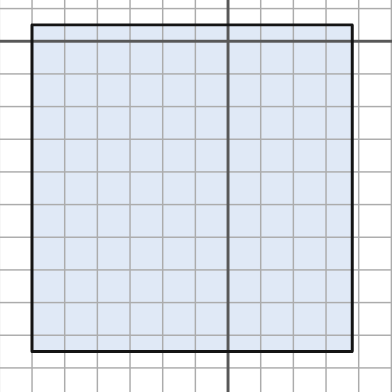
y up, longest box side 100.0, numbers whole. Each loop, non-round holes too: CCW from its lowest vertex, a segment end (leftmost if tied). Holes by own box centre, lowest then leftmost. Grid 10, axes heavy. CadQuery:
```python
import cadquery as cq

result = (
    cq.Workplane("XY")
    .moveTo(-60.0, -95.0)
    .lineTo(38.0, -95.0)
    .lineTo(38.0, 5.0)
    .lineTo(-60.0, 5.0)
    .close()
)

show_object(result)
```